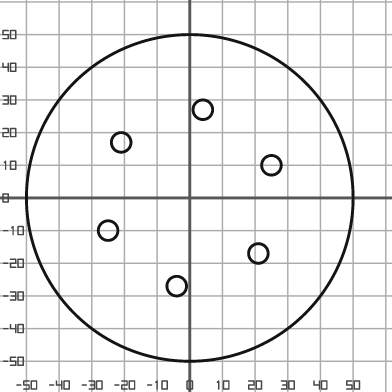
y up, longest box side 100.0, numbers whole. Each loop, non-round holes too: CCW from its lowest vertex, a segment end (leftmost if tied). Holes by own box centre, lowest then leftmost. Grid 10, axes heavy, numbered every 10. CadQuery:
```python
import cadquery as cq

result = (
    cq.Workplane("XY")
    .moveTo(0.0, 0.0)
    .circle(50.0)
    .moveTo(-4.0, -27.0)
    .circle(3.0)
    .moveTo(21.0, -17.0)
    .circle(3.0)
    .moveTo(-25.0, -10.0)
    .circle(3.0)
    .moveTo(25.0, 10.0)
    .circle(3.0)
    .moveTo(-21.0, 17.0)
    .circle(3.0)
    .moveTo(4.0, 27.0)
    .circle(3.0)
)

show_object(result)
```